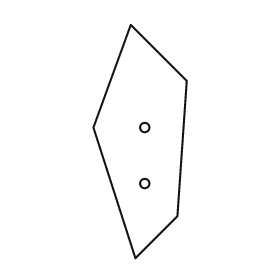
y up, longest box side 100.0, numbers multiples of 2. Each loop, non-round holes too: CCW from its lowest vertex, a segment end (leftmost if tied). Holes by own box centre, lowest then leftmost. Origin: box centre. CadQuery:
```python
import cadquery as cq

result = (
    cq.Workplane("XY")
    .moveTo(-2.0, -50.0)
    .lineTo(16.0, -32.0)
    .lineTo(20.0, 26.0)
    .lineTo(-4.0, 50.0)
    .lineTo(-20.0, 6.0)
    .close()
    .moveTo(2.0, -18.0)
    .circle(2.0)
    .moveTo(2.0, 6.0)
    .circle(2.0)
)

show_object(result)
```